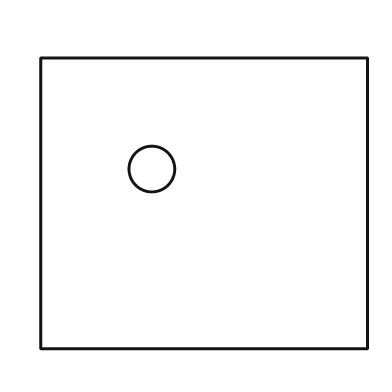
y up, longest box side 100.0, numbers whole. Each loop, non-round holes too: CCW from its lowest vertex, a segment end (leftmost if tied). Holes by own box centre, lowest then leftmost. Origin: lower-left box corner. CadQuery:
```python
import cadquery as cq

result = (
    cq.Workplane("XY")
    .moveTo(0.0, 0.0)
    .lineTo(100.0, 0.0)
    .lineTo(100.0, 89.0)
    .lineTo(0.0, 89.0)
    .close()
    .moveTo(34.0, 55.0)
    .circle(7.0)
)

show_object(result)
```